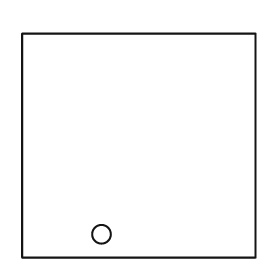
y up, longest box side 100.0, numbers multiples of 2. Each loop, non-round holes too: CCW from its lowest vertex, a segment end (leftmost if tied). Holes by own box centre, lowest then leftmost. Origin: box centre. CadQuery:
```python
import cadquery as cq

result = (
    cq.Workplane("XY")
    .moveTo(-50.0, -48.0)
    .lineTo(50.0, -48.0)
    .lineTo(50.0, 48.0)
    .lineTo(-50.0, 48.0)
    .close()
    .moveTo(-16.0, -38.0)
    .circle(4.0)
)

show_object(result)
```